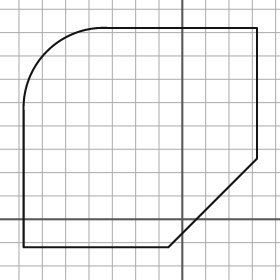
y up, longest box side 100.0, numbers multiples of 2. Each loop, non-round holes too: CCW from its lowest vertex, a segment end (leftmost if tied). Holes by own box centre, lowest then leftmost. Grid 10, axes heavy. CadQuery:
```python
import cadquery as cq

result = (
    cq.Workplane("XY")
    .moveTo(-68.0, -12.0)
    .lineTo(-6.0, -12.0)
    .lineTo(32.0, 26.0)
    .lineTo(32.0, 82.0)
    .lineTo(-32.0, 82.0)
    .threePointArc((-58.0, 72.0), (-68.0, 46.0))
    .close()
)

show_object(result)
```